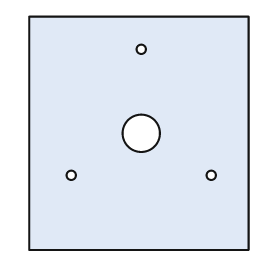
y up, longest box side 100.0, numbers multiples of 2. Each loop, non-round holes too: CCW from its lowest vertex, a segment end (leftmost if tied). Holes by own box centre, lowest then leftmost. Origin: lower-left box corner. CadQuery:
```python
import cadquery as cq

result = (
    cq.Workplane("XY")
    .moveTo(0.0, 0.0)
    .lineTo(94.0, 0.0)
    .lineTo(94.0, 100.0)
    .lineTo(0.0, 100.0)
    .close()
    .moveTo(18.0, 32.0)
    .circle(2.0)
    .moveTo(78.0, 32.0)
    .circle(2.0)
    .moveTo(48.0, 50.0)
    .circle(8.0)
    .moveTo(48.0, 86.0)
    .circle(2.0)
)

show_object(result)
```